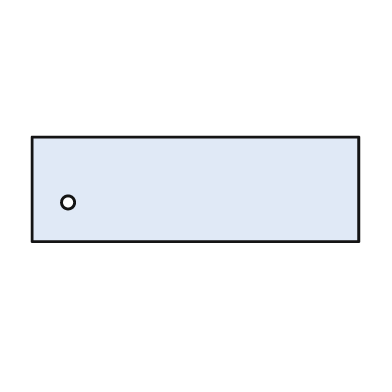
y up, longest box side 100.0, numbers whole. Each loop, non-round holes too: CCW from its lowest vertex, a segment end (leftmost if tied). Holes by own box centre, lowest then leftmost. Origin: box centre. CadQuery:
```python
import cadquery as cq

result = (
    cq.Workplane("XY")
    .moveTo(-50.0, -16.0)
    .lineTo(50.0, -16.0)
    .lineTo(50.0, 16.0)
    .lineTo(-50.0, 16.0)
    .close()
    .moveTo(-39.0, -4.0)
    .circle(2.0)
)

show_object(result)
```